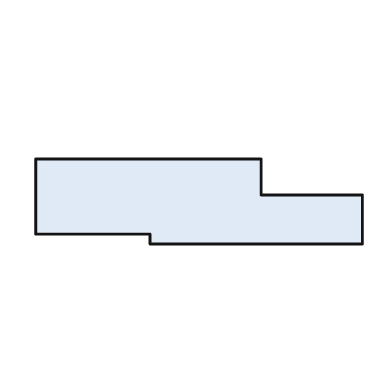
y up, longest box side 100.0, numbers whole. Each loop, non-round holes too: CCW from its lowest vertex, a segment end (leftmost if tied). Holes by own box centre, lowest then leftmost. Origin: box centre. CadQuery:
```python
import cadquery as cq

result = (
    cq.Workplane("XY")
    .moveTo(-15.0, -13.0)
    .lineTo(50.0, -13.0)
    .lineTo(50.0, 2.0)
    .lineTo(19.0, 2.0)
    .lineTo(19.0, 13.0)
    .lineTo(-50.0, 13.0)
    .lineTo(-50.0, -10.0)
    .lineTo(-15.0, -10.0)
    .close()
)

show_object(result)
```